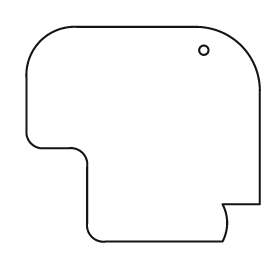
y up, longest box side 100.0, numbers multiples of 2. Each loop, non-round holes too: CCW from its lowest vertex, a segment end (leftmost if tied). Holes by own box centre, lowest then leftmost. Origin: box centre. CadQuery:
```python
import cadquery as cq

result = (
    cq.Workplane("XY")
    .moveTo(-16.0, -46.0)
    .lineTo(34.0, -46.0)
    .threePointArc((36.0, -38.0), (34.0, -30.0))
    .lineTo(50.0, -30.0)
    .lineTo(50.0, 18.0)
    .threePointArc((42.0, 38.0), (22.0, 46.0))
    .lineTo(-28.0, 46.0)
    .threePointArc((-44.0, 40.0), (-50.0, 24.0))
    .lineTo(-50.0, 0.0)
    .threePointArc((-48.0, -4.0), (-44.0, -6.0))
    .lineTo(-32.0, -6.0)
    .threePointArc((-26.0, -8.0), (-24.0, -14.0))
    .lineTo(-24.0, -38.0)
    .threePointArc((-22.0, -44.0), (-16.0, -46.0))
    .close()
    .moveTo(26.0, 36.0)
    .circle(2.0)
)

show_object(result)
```